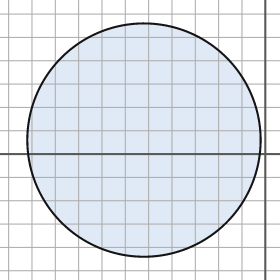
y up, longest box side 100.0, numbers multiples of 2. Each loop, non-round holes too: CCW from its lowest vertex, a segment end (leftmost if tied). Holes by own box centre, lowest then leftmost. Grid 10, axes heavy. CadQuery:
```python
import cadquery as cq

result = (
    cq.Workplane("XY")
    .moveTo(-52.0, 6.0)
    .circle(50.0)
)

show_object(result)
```